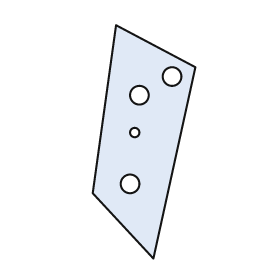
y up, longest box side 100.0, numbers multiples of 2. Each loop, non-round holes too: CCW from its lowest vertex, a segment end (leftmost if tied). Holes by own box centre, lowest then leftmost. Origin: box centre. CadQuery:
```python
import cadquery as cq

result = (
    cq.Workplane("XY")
    .moveTo(4.0, -50.0)
    .lineTo(22.0, 32.0)
    .lineTo(-12.0, 50.0)
    .lineTo(-22.0, -22.0)
    .close()
    .moveTo(-6.0, -18.0)
    .circle(4.0)
    .moveTo(-4.0, 4.0)
    .circle(2.0)
    .moveTo(-2.0, 20.0)
    .circle(4.0)
    .moveTo(12.0, 28.0)
    .circle(4.0)
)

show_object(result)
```